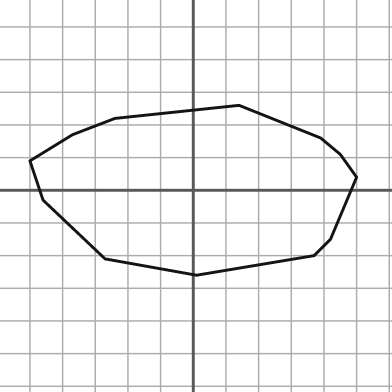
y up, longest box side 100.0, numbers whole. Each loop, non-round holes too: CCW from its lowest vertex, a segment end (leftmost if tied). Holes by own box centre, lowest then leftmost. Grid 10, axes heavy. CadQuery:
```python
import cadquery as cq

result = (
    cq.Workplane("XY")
    .moveTo(1.0, -26.0)
    .lineTo(37.0, -20.0)
    .lineTo(42.0, -15.0)
    .lineTo(50.0, 4.0)
    .lineTo(45.0, 11.0)
    .lineTo(39.0, 16.0)
    .lineTo(14.0, 26.0)
    .lineTo(-24.0, 22.0)
    .lineTo(-37.0, 17.0)
    .lineTo(-50.0, 9.0)
    .lineTo(-46.0, -3.0)
    .lineTo(-27.0, -21.0)
    .close()
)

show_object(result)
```